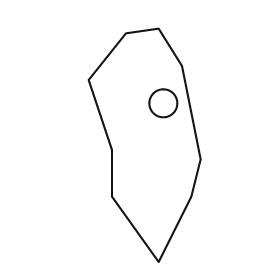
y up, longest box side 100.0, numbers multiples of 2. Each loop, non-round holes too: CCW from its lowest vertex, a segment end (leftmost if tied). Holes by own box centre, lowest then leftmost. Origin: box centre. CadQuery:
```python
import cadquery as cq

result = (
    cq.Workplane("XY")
    .moveTo(6.0, -50.0)
    .lineTo(20.0, -22.0)
    .lineTo(24.0, -6.0)
    .lineTo(16.0, 34.0)
    .lineTo(6.0, 50.0)
    .lineTo(-8.0, 48.0)
    .lineTo(-24.0, 28.0)
    .lineTo(-14.0, -2.0)
    .lineTo(-14.0, -22.0)
    .close()
    .moveTo(8.0, 18.0)
    .circle(6.0)
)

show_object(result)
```